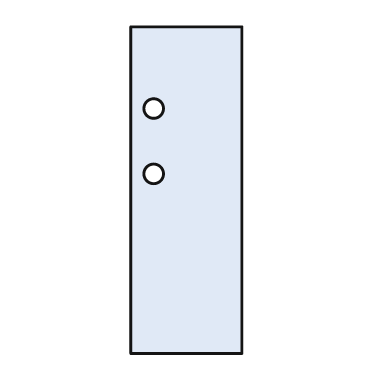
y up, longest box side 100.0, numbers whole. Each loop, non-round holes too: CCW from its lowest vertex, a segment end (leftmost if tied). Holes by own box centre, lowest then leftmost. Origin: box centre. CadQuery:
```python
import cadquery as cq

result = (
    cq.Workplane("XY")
    .moveTo(-17.0, -50.0)
    .lineTo(17.0, -50.0)
    .lineTo(17.0, 50.0)
    .lineTo(-17.0, 50.0)
    .close()
    .moveTo(-10.0, 5.0)
    .circle(3.0)
    .moveTo(-10.0, 25.0)
    .circle(3.0)
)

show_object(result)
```